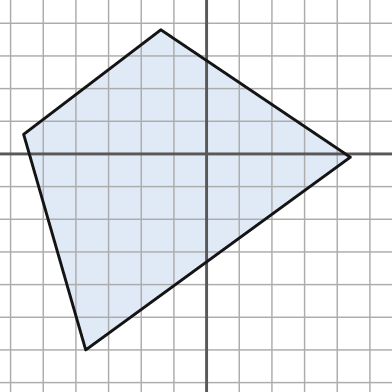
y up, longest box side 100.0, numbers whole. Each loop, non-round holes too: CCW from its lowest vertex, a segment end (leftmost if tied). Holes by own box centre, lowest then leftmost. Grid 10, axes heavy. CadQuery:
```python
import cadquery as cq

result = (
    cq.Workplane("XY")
    .moveTo(-37.0, -60.0)
    .lineTo(44.0, -1.0)
    .lineTo(-14.0, 38.0)
    .lineTo(-56.0, 6.0)
    .close()
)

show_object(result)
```